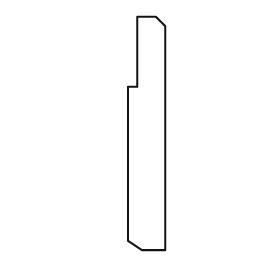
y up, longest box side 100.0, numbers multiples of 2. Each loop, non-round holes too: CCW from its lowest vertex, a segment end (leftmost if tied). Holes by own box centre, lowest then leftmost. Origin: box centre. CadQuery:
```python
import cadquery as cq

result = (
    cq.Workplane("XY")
    .moveTo(-2.0, -50.0)
    .lineTo(8.0, -50.0)
    .lineTo(8.0, 46.0)
    .lineTo(4.0, 50.0)
    .lineTo(-4.0, 50.0)
    .lineTo(-4.0, 20.0)
    .lineTo(-8.0, 20.0)
    .lineTo(-8.0, -46.0)
    .close()
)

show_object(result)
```